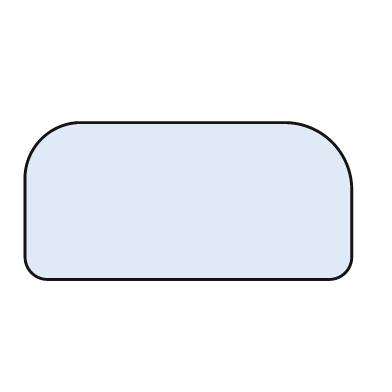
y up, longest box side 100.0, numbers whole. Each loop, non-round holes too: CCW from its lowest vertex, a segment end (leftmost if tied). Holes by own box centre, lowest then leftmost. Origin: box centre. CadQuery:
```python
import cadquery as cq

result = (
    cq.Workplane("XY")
    .moveTo(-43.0, -24.0)
    .lineTo(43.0, -24.0)
    .threePointArc((48.0, -22.0), (50.0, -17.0))
    .lineTo(50.0, 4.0)
    .threePointArc((44.0, 18.0), (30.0, 24.0))
    .lineTo(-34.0, 24.0)
    .threePointArc((-45.0, 19.0), (-50.0, 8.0))
    .lineTo(-50.0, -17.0)
    .threePointArc((-48.0, -22.0), (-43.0, -24.0))
    .close()
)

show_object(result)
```